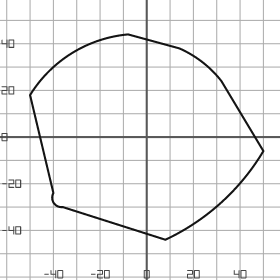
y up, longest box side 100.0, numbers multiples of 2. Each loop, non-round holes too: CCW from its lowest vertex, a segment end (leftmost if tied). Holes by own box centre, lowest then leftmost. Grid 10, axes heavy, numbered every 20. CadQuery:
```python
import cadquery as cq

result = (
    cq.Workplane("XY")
    .moveTo(8.0, -44.0)
    .threePointArc((32.0, -28.0), (50.0, -6.0))
    .lineTo(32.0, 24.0)
    .threePointArc((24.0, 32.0), (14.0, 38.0))
    .lineTo(-8.0, 44.0)
    .threePointArc((-32.0, 36.0), (-50.0, 18.0))
    .lineTo(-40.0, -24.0)
    .threePointArc((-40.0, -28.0), (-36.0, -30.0))
    .close()
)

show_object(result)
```